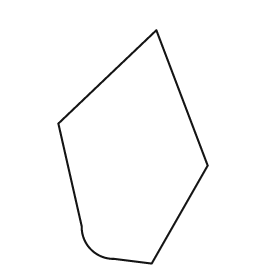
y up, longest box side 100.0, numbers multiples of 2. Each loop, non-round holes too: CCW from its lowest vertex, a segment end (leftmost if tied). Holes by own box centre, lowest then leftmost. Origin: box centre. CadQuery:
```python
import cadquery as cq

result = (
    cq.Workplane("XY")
    .moveTo(8.0, -50.0)
    .lineTo(32.0, -8.0)
    .lineTo(10.0, 50.0)
    .lineTo(-32.0, 10.0)
    .lineTo(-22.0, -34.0)
    .threePointArc((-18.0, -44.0), (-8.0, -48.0))
    .close()
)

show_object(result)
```